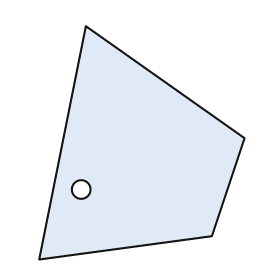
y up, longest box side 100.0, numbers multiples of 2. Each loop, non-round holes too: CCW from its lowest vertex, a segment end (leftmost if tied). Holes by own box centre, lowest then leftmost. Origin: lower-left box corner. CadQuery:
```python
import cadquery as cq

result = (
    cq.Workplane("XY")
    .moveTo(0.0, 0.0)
    .lineTo(74.0, 10.0)
    .lineTo(88.0, 52.0)
    .lineTo(20.0, 100.0)
    .close()
    .moveTo(18.0, 30.0)
    .circle(4.0)
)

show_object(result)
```